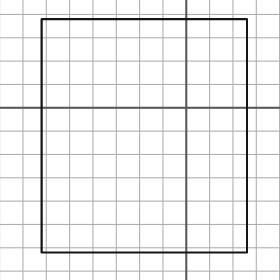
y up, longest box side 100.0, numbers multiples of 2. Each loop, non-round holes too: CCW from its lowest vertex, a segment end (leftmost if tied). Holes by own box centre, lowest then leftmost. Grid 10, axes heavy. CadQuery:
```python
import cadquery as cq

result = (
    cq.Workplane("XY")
    .moveTo(-62.0, -62.0)
    .lineTo(26.0, -62.0)
    .lineTo(26.0, 38.0)
    .lineTo(-62.0, 38.0)
    .close()
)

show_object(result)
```